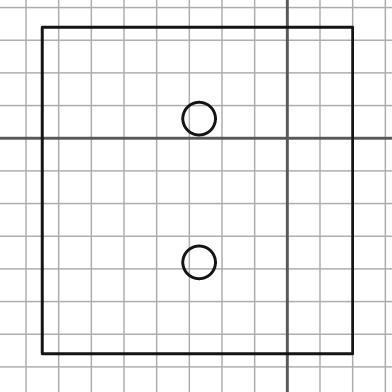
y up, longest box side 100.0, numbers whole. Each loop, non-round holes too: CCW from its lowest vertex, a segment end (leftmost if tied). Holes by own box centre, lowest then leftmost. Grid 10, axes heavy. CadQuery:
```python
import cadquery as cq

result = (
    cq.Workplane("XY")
    .moveTo(-75.0, -66.0)
    .lineTo(20.0, -66.0)
    .lineTo(20.0, 34.0)
    .lineTo(-75.0, 34.0)
    .close()
    .moveTo(-27.0, -38.0)
    .circle(5.0)
    .moveTo(-27.0, 6.0)
    .circle(5.0)
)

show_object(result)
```